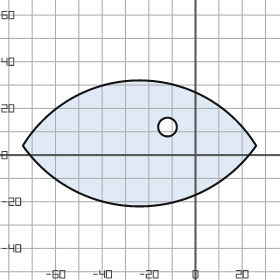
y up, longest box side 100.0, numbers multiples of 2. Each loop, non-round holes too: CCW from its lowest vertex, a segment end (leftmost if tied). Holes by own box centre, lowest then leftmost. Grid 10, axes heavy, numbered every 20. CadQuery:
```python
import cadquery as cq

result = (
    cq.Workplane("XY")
    .moveTo(-74.0, 4.0)
    .threePointArc((-24.0, -22.0), (26.0, 4.0))
    .threePointArc((-24.0, 32.0), (-74.0, 4.0))
    .close()
    .moveTo(-12.0, 12.0)
    .circle(4.0)
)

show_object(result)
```